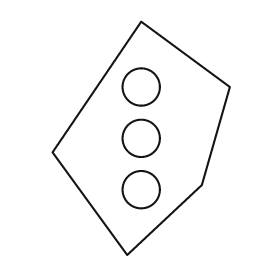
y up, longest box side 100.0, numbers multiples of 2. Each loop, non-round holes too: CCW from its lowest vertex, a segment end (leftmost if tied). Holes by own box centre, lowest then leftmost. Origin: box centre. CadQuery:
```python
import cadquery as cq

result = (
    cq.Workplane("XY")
    .moveTo(-6.0, -50.0)
    .lineTo(26.0, -20.0)
    .lineTo(38.0, 22.0)
    .lineTo(0.0, 50.0)
    .lineTo(-38.0, -6.0)
    .close()
    .moveTo(0.0, -22.0)
    .circle(8.0)
    .moveTo(0.0, 0.0)
    .circle(8.0)
    .moveTo(0.0, 22.0)
    .circle(8.0)
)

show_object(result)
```